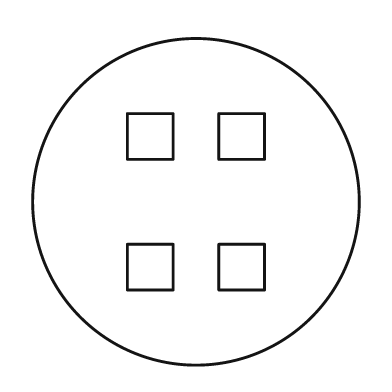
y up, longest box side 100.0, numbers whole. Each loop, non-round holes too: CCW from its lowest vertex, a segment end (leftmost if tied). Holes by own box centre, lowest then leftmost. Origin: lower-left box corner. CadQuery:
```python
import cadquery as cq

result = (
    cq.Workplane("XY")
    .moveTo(50.0, 50.0)
    .circle(50.0)
    .moveTo(29.0, 23.0)
    .lineTo(43.0, 23.0)
    .lineTo(43.0, 37.0)
    .lineTo(29.0, 37.0)
    .close()
    .moveTo(57.0, 23.0)
    .lineTo(71.0, 23.0)
    .lineTo(71.0, 37.0)
    .lineTo(57.0, 37.0)
    .close()
    .moveTo(29.0, 63.0)
    .lineTo(43.0, 63.0)
    .lineTo(43.0, 77.0)
    .lineTo(29.0, 77.0)
    .close()
    .moveTo(57.0, 63.0)
    .lineTo(71.0, 63.0)
    .lineTo(71.0, 77.0)
    .lineTo(57.0, 77.0)
    .close()
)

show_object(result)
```